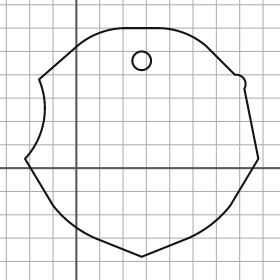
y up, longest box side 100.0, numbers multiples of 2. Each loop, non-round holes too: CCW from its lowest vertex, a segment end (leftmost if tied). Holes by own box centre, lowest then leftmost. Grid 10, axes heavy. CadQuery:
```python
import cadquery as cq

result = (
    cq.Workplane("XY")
    .moveTo(28.0, -38.0)
    .lineTo(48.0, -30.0)
    .threePointArc((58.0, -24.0), (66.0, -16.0))
    .lineTo(78.0, 4.0)
    .lineTo(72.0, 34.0)
    .threePointArc((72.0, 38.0), (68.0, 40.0))
    .lineTo(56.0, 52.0)
    .threePointArc((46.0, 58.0), (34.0, 60.0))
    .lineTo(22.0, 60.0)
    .threePointArc((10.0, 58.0), (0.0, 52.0))
    .lineTo(-16.0, 38.0)
    .threePointArc((-14.0, 20.0), (-22.0, 4.0))
    .lineTo(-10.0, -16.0)
    .threePointArc((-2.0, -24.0), (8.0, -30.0))
    .close()
    .moveTo(28.0, 46.0)
    .circle(4.0)
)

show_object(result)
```